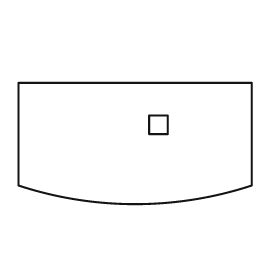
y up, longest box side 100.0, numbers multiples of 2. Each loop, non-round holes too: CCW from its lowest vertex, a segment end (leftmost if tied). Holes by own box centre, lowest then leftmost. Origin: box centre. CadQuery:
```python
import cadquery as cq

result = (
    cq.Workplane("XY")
    .moveTo(-50.0, -18.0)
    .threePointArc((0.0, -26.0), (50.0, -18.0))
    .lineTo(50.0, 26.0)
    .lineTo(-50.0, 26.0)
    .close()
    .moveTo(6.0, 4.0)
    .lineTo(14.0, 4.0)
    .lineTo(14.0, 12.0)
    .lineTo(6.0, 12.0)
    .close()
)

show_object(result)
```